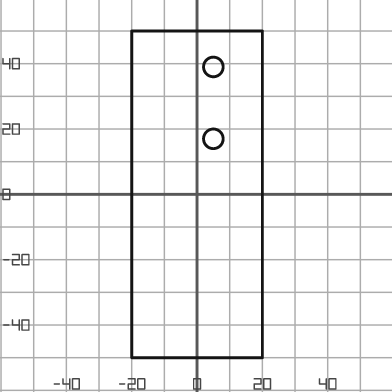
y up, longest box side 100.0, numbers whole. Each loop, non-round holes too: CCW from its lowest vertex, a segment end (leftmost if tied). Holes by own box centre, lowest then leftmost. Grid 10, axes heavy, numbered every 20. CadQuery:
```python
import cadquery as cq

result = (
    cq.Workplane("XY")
    .moveTo(-20.0, -50.0)
    .lineTo(20.0, -50.0)
    .lineTo(20.0, 50.0)
    .lineTo(-20.0, 50.0)
    .close()
    .moveTo(5.0, 17.0)
    .circle(3.0)
    .moveTo(5.0, 39.0)
    .circle(3.0)
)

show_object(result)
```